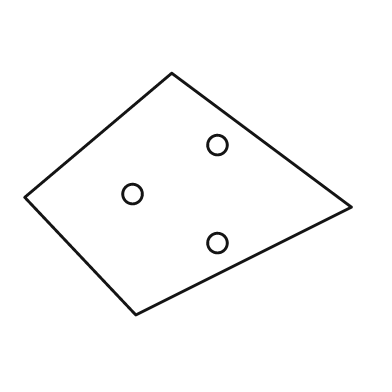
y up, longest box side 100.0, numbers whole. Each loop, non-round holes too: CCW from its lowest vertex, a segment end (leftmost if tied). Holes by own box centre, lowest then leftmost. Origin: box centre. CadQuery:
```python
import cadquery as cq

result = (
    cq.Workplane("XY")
    .moveTo(-16.0, -37.0)
    .lineTo(50.0, -4.0)
    .lineTo(-5.0, 37.0)
    .lineTo(-50.0, -1.0)
    .close()
    .moveTo(9.0, -15.0)
    .circle(3.0)
    .moveTo(-17.0, 0.0)
    .circle(3.0)
    .moveTo(9.0, 15.0)
    .circle(3.0)
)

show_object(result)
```